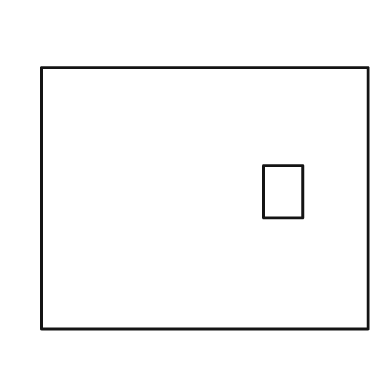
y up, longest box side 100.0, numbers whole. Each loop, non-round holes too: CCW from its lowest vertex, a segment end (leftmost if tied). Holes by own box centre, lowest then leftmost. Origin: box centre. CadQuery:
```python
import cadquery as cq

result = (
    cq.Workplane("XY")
    .moveTo(-50.0, -40.0)
    .lineTo(50.0, -40.0)
    .lineTo(50.0, 40.0)
    .lineTo(-50.0, 40.0)
    .close()
    .moveTo(18.0, -6.0)
    .lineTo(30.0, -6.0)
    .lineTo(30.0, 10.0)
    .lineTo(18.0, 10.0)
    .close()
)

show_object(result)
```